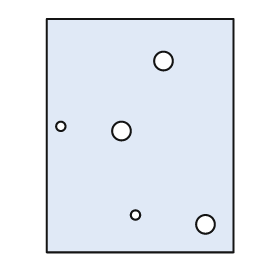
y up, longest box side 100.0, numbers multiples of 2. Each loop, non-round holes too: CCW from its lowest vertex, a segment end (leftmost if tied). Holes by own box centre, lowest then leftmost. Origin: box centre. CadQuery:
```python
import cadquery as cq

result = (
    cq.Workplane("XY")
    .moveTo(-40.0, -50.0)
    .lineTo(40.0, -50.0)
    .lineTo(40.0, 50.0)
    .lineTo(-40.0, 50.0)
    .close()
    .moveTo(28.0, -38.0)
    .circle(4.0)
    .moveTo(-2.0, -34.0)
    .circle(2.0)
    .moveTo(-8.0, 2.0)
    .circle(4.0)
    .moveTo(-34.0, 4.0)
    .circle(2.0)
    .moveTo(10.0, 32.0)
    .circle(4.0)
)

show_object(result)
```